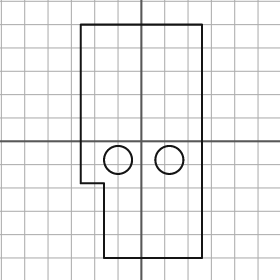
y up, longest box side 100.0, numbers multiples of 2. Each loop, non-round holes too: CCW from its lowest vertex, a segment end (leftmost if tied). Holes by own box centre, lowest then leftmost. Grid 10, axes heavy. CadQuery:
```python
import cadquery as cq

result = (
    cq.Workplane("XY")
    .moveTo(-16.0, -50.0)
    .lineTo(26.0, -50.0)
    .lineTo(26.0, 50.0)
    .lineTo(-26.0, 50.0)
    .lineTo(-26.0, -18.0)
    .lineTo(-16.0, -18.0)
    .close()
    .moveTo(-10.0, -8.0)
    .circle(6.0)
    .moveTo(12.0, -8.0)
    .circle(6.0)
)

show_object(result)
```